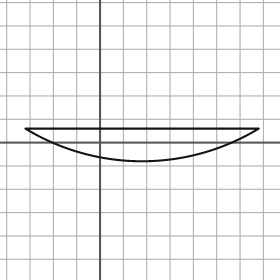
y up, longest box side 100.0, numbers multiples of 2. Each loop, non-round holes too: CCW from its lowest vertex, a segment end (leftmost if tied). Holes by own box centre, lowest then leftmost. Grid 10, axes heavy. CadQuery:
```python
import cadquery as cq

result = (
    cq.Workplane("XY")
    .moveTo(-32.0, 6.0)
    .threePointArc((18.0, -8.0), (68.0, 6.0))
    .close()
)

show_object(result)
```